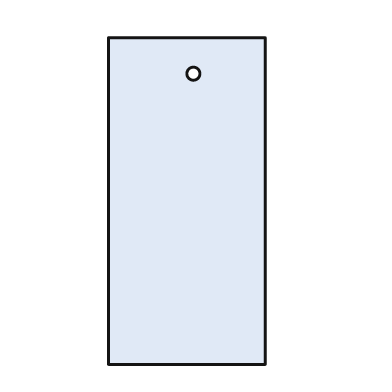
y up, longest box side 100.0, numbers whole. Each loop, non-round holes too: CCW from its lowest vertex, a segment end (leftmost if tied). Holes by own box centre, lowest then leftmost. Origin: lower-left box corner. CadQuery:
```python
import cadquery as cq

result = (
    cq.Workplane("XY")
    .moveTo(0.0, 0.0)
    .lineTo(48.0, 0.0)
    .lineTo(48.0, 100.0)
    .lineTo(0.0, 100.0)
    .close()
    .moveTo(26.0, 89.0)
    .circle(2.0)
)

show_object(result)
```